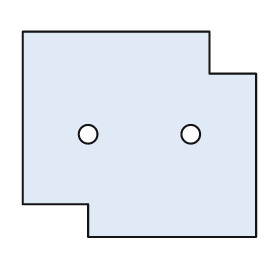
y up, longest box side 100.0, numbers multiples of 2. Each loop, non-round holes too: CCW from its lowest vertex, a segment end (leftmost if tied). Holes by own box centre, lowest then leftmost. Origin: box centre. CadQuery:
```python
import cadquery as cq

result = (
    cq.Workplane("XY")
    .moveTo(-22.0, -44.0)
    .lineTo(50.0, -44.0)
    .lineTo(50.0, 26.0)
    .lineTo(30.0, 26.0)
    .lineTo(30.0, 44.0)
    .lineTo(-50.0, 44.0)
    .lineTo(-50.0, -30.0)
    .lineTo(-22.0, -30.0)
    .close()
    .moveTo(-22.0, 0.0)
    .circle(4.0)
    .moveTo(22.0, 0.0)
    .circle(4.0)
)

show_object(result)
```